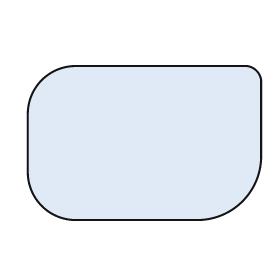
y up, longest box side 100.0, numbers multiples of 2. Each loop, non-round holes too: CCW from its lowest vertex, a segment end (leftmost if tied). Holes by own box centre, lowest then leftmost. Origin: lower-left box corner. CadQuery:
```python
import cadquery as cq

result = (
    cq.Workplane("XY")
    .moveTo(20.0, 0.0)
    .lineTo(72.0, 0.0)
    .threePointArc((92.0, 8.0), (100.0, 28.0))
    .lineTo(100.0, 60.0)
    .threePointArc((98.0, 64.0), (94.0, 66.0))
    .lineTo(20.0, 66.0)
    .threePointArc((6.0, 60.0), (0.0, 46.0))
    .lineTo(0.0, 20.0)
    .threePointArc((6.0, 6.0), (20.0, 0.0))
    .close()
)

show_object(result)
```